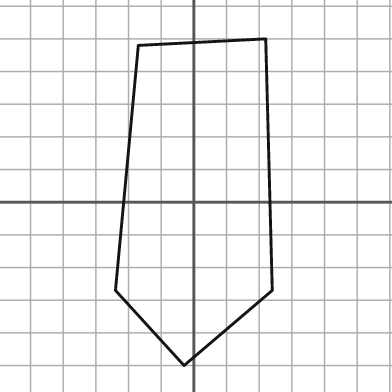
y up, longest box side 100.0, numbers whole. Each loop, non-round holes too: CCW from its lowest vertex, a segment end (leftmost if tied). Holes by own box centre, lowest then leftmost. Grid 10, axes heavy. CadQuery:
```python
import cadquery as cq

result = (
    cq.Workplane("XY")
    .moveTo(-3.0, -50.0)
    .lineTo(24.0, -27.0)
    .lineTo(22.0, 50.0)
    .lineTo(-17.0, 48.0)
    .lineTo(-24.0, -27.0)
    .close()
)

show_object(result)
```